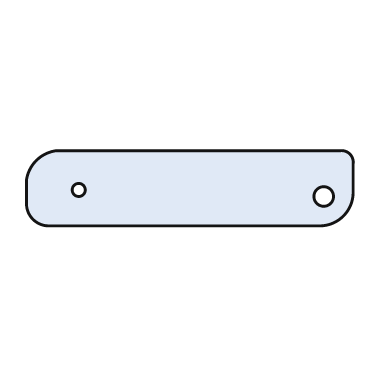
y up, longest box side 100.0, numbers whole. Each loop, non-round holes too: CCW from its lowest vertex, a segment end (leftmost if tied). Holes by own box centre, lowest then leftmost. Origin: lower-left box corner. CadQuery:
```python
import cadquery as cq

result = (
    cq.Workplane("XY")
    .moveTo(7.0, 0.0)
    .lineTo(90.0, 0.0)
    .threePointArc((97.0, 3.0), (100.0, 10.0))
    .lineTo(100.0, 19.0)
    .threePointArc((99.0, 22.0), (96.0, 23.0))
    .lineTo(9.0, 23.0)
    .threePointArc((3.0, 20.0), (0.0, 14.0))
    .lineTo(0.0, 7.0)
    .threePointArc((2.0, 2.0), (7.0, 0.0))
    .close()
    .moveTo(91.0, 9.0)
    .circle(3.0)
    .moveTo(16.0, 11.0)
    .circle(2.0)
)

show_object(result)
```